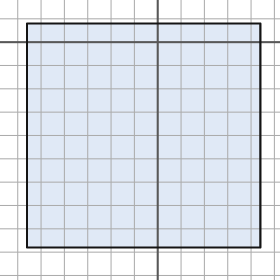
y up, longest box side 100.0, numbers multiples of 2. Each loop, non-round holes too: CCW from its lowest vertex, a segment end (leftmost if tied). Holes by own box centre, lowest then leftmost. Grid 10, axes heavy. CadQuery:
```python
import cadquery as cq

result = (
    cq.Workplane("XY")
    .moveTo(-56.0, -88.0)
    .lineTo(44.0, -88.0)
    .lineTo(44.0, 8.0)
    .lineTo(-56.0, 8.0)
    .close()
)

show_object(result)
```